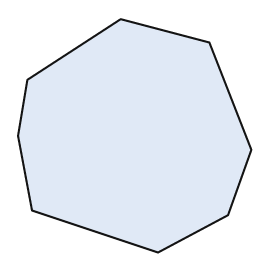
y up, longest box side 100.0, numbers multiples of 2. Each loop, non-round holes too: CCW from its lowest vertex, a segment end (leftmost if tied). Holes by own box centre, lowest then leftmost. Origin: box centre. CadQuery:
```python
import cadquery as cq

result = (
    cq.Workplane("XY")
    .moveTo(10.0, -50.0)
    .lineTo(40.0, -34.0)
    .lineTo(50.0, -6.0)
    .lineTo(32.0, 40.0)
    .lineTo(-6.0, 50.0)
    .lineTo(-46.0, 24.0)
    .lineTo(-50.0, 0.0)
    .lineTo(-44.0, -32.0)
    .close()
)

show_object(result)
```